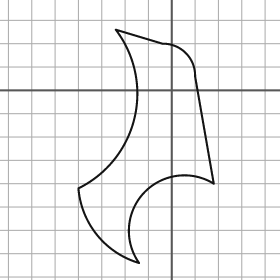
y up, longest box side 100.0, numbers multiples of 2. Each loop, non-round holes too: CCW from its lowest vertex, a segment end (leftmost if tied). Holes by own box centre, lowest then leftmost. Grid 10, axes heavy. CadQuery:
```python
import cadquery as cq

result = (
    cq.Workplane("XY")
    .moveTo(-14.0, -74.0)
    .threePointArc((-12.0, -44.0), (18.0, -40.0))
    .lineTo(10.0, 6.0)
    .threePointArc((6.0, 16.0), (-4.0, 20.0))
    .lineTo(-24.0, 26.0)
    .threePointArc((-16.0, -12.0), (-40.0, -42.0))
    .threePointArc((-32.0, -62.0), (-14.0, -74.0))
    .close()
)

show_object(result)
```